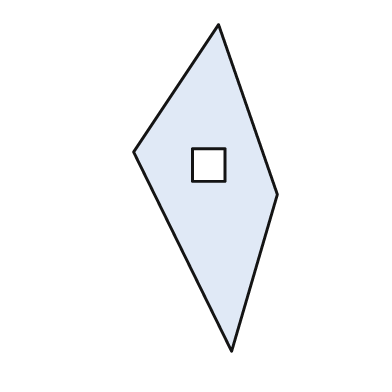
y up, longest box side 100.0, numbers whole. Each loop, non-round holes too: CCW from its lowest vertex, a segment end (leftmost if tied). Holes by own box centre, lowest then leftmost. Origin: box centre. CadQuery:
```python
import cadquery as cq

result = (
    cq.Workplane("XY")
    .moveTo(8.0, -50.0)
    .lineTo(22.0, -2.0)
    .lineTo(4.0, 50.0)
    .lineTo(-22.0, 11.0)
    .close()
    .moveTo(-4.0, 2.0)
    .lineTo(6.0, 2.0)
    .lineTo(6.0, 12.0)
    .lineTo(-4.0, 12.0)
    .close()
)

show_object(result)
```